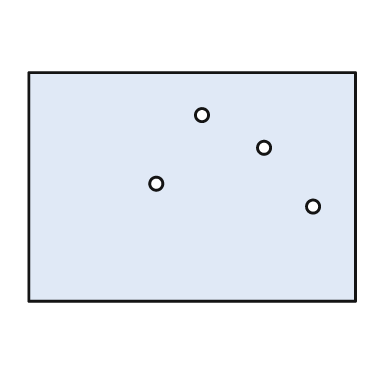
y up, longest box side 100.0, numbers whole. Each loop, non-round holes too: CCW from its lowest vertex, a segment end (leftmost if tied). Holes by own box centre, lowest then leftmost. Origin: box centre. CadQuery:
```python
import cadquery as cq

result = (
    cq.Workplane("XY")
    .moveTo(-50.0, -35.0)
    .lineTo(50.0, -35.0)
    .lineTo(50.0, 35.0)
    .lineTo(-50.0, 35.0)
    .close()
    .moveTo(37.0, -6.0)
    .circle(2.0)
    .moveTo(-11.0, 1.0)
    .circle(2.0)
    .moveTo(22.0, 12.0)
    .circle(2.0)
    .moveTo(3.0, 22.0)
    .circle(2.0)
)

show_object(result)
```